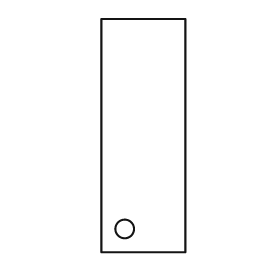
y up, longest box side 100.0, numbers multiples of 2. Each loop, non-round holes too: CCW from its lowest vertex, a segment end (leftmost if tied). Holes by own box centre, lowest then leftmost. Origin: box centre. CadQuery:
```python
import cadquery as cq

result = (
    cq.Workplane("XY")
    .moveTo(-18.0, -50.0)
    .lineTo(18.0, -50.0)
    .lineTo(18.0, 50.0)
    .lineTo(-18.0, 50.0)
    .close()
    .moveTo(-8.0, -40.0)
    .circle(4.0)
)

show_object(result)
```